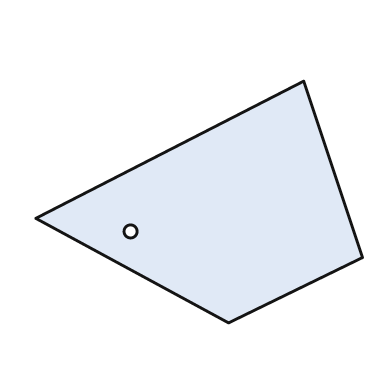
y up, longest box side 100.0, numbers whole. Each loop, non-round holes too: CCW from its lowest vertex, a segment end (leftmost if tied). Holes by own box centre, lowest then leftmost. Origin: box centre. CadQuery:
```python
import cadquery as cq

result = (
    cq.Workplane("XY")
    .moveTo(9.0, -37.0)
    .lineTo(50.0, -17.0)
    .lineTo(32.0, 37.0)
    .lineTo(-50.0, -5.0)
    .close()
    .moveTo(-21.0, -9.0)
    .circle(2.0)
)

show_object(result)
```